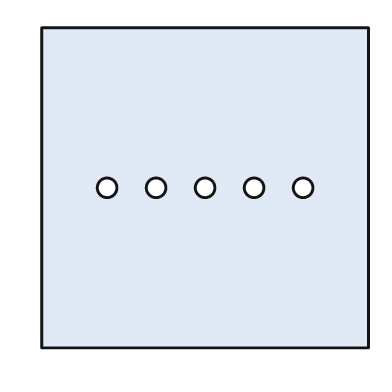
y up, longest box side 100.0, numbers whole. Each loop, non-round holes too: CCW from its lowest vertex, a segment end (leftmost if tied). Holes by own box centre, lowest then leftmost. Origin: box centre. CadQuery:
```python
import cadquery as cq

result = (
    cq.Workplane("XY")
    .moveTo(-50.0, -49.0)
    .lineTo(50.0, -49.0)
    .lineTo(50.0, 49.0)
    .lineTo(-50.0, 49.0)
    .close()
    .moveTo(-30.0, 0.0)
    .circle(3.0)
    .moveTo(-15.0, 0.0)
    .circle(3.0)
    .moveTo(0.0, 0.0)
    .circle(3.0)
    .moveTo(15.0, 0.0)
    .circle(3.0)
    .moveTo(30.0, 0.0)
    .circle(3.0)
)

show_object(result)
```